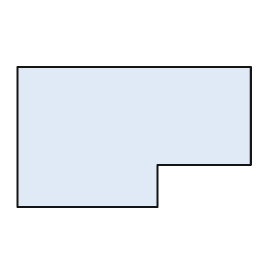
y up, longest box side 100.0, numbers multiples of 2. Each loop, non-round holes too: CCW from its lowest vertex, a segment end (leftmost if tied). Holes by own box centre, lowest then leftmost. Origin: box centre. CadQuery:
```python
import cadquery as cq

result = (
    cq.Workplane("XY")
    .moveTo(-50.0, -30.0)
    .lineTo(10.0, -30.0)
    .lineTo(10.0, -12.0)
    .lineTo(50.0, -12.0)
    .lineTo(50.0, 30.0)
    .lineTo(-50.0, 30.0)
    .close()
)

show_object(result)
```